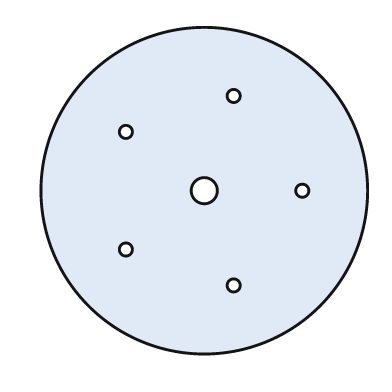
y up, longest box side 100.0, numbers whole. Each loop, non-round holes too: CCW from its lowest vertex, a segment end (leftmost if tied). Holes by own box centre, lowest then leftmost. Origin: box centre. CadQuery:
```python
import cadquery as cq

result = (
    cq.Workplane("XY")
    .moveTo(0.0, 0.0)
    .circle(50.0)
    .moveTo(9.0, -29.0)
    .circle(2.0)
    .moveTo(-24.0, -18.0)
    .circle(2.0)
    .moveTo(0.0, 0.0)
    .circle(4.0)
    .moveTo(30.0, 0.0)
    .circle(2.0)
    .moveTo(-24.0, 18.0)
    .circle(2.0)
    .moveTo(9.0, 29.0)
    .circle(2.0)
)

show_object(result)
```